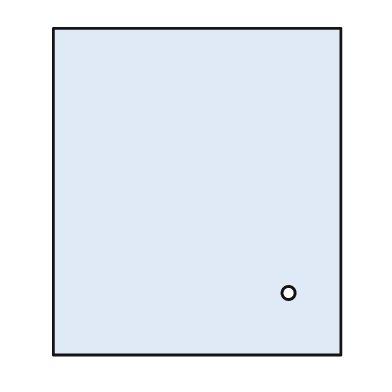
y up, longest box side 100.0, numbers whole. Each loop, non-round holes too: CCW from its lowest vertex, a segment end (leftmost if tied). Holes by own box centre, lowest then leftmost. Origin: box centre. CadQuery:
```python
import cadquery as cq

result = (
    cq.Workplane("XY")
    .moveTo(-44.0, -50.0)
    .lineTo(44.0, -50.0)
    .lineTo(44.0, 50.0)
    .lineTo(-44.0, 50.0)
    .close()
    .moveTo(28.0, -31.0)
    .circle(2.0)
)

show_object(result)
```